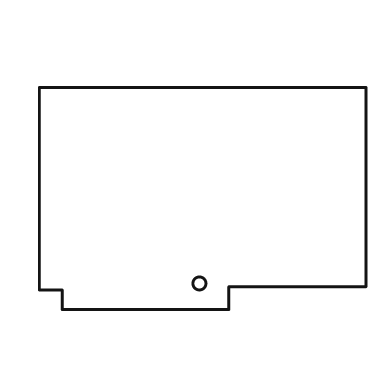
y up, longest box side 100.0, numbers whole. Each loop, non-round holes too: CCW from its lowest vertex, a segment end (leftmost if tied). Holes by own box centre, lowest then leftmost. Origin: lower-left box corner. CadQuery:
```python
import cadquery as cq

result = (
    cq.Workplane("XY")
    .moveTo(7.0, 0.0)
    .lineTo(58.0, 0.0)
    .lineTo(58.0, 7.0)
    .lineTo(100.0, 7.0)
    .lineTo(100.0, 68.0)
    .lineTo(0.0, 68.0)
    .lineTo(0.0, 6.0)
    .lineTo(7.0, 6.0)
    .close()
    .moveTo(49.0, 8.0)
    .circle(2.0)
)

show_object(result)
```